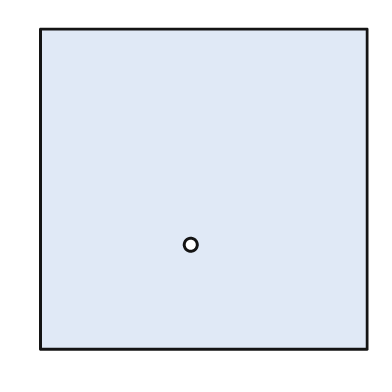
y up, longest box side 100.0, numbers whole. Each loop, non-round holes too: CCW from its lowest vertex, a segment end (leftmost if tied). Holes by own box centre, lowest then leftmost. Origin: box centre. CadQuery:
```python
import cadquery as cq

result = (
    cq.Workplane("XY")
    .moveTo(-50.0, -49.0)
    .lineTo(50.0, -49.0)
    .lineTo(50.0, 49.0)
    .lineTo(-50.0, 49.0)
    .close()
    .moveTo(-4.0, -17.0)
    .circle(2.0)
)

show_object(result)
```